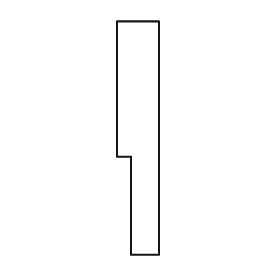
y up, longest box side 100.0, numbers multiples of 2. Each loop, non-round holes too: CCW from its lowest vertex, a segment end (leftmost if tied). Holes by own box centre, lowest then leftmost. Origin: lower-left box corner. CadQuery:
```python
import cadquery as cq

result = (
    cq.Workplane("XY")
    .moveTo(6.0, 0.0)
    .lineTo(18.0, 0.0)
    .lineTo(18.0, 100.0)
    .lineTo(0.0, 100.0)
    .lineTo(0.0, 42.0)
    .lineTo(6.0, 42.0)
    .close()
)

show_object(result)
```